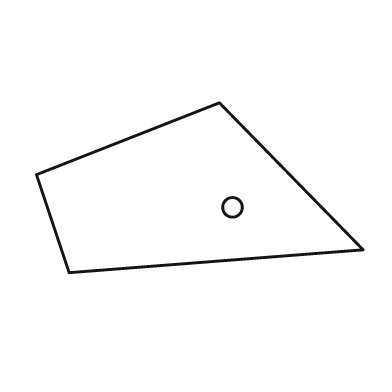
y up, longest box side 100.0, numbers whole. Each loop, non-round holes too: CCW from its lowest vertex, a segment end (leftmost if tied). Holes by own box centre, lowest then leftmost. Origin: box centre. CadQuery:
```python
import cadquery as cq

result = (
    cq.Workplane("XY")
    .moveTo(-40.0, -26.0)
    .lineTo(50.0, -19.0)
    .lineTo(6.0, 26.0)
    .lineTo(-50.0, 4.0)
    .close()
    .moveTo(10.0, -6.0)
    .circle(3.0)
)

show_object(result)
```